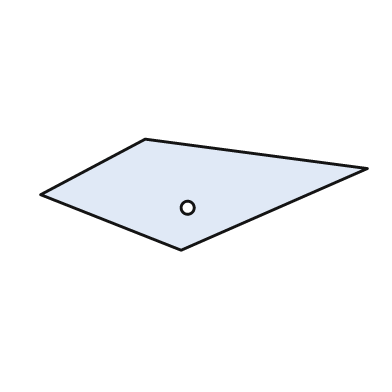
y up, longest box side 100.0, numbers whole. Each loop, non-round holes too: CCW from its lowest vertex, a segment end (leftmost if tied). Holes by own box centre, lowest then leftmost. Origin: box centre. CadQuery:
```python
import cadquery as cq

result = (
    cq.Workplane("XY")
    .moveTo(-7.0, -17.0)
    .lineTo(50.0, 8.0)
    .lineTo(-18.0, 17.0)
    .lineTo(-50.0, 0.0)
    .close()
    .moveTo(-5.0, -4.0)
    .circle(2.0)
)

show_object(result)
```